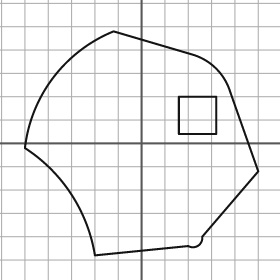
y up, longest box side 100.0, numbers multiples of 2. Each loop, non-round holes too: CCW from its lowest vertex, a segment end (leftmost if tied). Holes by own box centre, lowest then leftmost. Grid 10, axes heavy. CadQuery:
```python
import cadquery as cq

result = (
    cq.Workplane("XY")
    .moveTo(-20.0, -48.0)
    .lineTo(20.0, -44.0)
    .threePointArc((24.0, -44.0), (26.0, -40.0))
    .lineTo(50.0, -12.0)
    .lineTo(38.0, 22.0)
    .threePointArc((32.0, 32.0), (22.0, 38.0))
    .lineTo(-12.0, 48.0)
    .threePointArc((-38.0, 28.0), (-50.0, -2.0))
    .threePointArc((-30.0, -22.0), (-20.0, -48.0))
    .close()
    .moveTo(16.0, 4.0)
    .lineTo(32.0, 4.0)
    .lineTo(32.0, 20.0)
    .lineTo(16.0, 20.0)
    .close()
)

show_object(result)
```